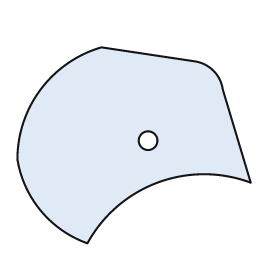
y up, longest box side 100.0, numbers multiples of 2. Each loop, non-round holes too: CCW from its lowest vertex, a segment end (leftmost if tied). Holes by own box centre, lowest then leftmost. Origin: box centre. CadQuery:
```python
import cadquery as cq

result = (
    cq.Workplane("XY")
    .moveTo(-20.0, -42.0)
    .threePointArc((10.0, -16.0), (50.0, -16.0))
    .lineTo(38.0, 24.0)
    .threePointArc((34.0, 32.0), (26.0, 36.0))
    .lineTo(-14.0, 42.0)
    .threePointArc((-40.0, 24.0), (-50.0, -6.0))
    .threePointArc((-40.0, -28.0), (-20.0, -42.0))
    .close()
    .moveTo(6.0, 2.0)
    .circle(4.0)
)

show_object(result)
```